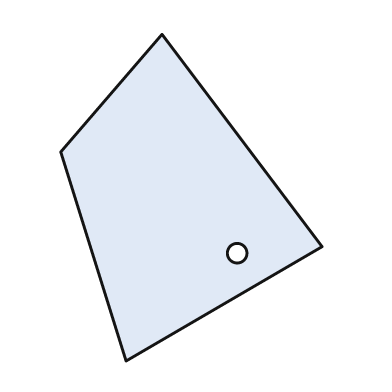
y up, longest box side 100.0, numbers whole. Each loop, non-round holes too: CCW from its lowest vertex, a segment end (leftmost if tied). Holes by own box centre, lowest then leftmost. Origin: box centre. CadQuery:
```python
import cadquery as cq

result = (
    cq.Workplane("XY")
    .moveTo(-20.0, -50.0)
    .lineTo(40.0, -15.0)
    .lineTo(-9.0, 50.0)
    .lineTo(-40.0, 14.0)
    .close()
    .moveTo(14.0, -17.0)
    .circle(3.0)
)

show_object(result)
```